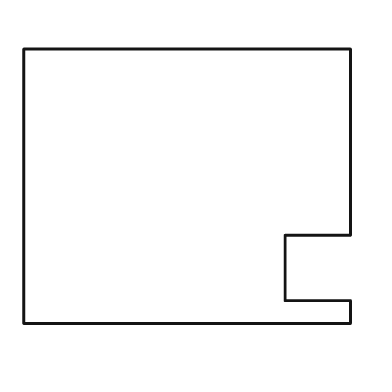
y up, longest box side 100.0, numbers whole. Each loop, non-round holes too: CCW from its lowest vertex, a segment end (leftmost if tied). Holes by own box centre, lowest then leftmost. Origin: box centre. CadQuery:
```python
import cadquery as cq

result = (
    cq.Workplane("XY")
    .moveTo(-50.0, -42.0)
    .lineTo(50.0, -42.0)
    .lineTo(50.0, -35.0)
    .lineTo(30.0, -35.0)
    .lineTo(30.0, -15.0)
    .lineTo(50.0, -15.0)
    .lineTo(50.0, 42.0)
    .lineTo(-50.0, 42.0)
    .close()
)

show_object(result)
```